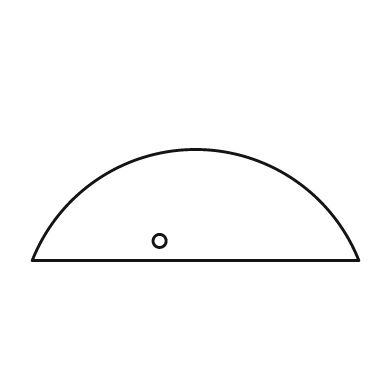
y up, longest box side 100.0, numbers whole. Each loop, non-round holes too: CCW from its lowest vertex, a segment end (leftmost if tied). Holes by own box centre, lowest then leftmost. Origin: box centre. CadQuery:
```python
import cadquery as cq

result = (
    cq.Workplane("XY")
    .moveTo(-50.0, -17.0)
    .lineTo(50.0, -17.0)
    .threePointArc((0.0, 17.0), (-50.0, -17.0))
    .close()
    .moveTo(-11.0, -11.0)
    .circle(2.0)
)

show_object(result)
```